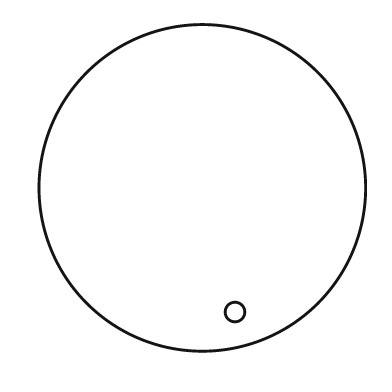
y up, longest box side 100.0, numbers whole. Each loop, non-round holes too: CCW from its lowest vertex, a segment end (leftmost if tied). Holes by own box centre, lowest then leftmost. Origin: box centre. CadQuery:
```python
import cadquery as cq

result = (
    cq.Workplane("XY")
    .moveTo(0.0, 0.0)
    .circle(50.0)
    .moveTo(10.0, -38.0)
    .circle(3.0)
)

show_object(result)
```